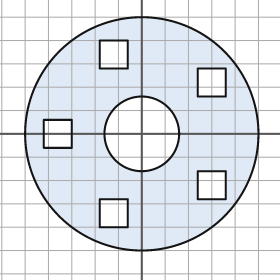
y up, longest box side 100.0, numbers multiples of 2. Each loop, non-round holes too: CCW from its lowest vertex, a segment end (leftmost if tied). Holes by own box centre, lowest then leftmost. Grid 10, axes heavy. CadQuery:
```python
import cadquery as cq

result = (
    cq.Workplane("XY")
    .moveTo(0.0, 0.0)
    .circle(50.0)
    .moveTo(-18.0, -40.0)
    .lineTo(-6.0, -40.0)
    .lineTo(-6.0, -28.0)
    .lineTo(-18.0, -28.0)
    .close()
    .moveTo(24.0, -28.0)
    .lineTo(36.0, -28.0)
    .lineTo(36.0, -16.0)
    .lineTo(24.0, -16.0)
    .close()
    .moveTo(-42.0, -6.0)
    .lineTo(-30.0, -6.0)
    .lineTo(-30.0, 6.0)
    .lineTo(-42.0, 6.0)
    .close()
    .moveTo(0.0, 0.0)
    .circle(16.0)
    .moveTo(24.0, 16.0)
    .lineTo(36.0, 16.0)
    .lineTo(36.0, 28.0)
    .lineTo(24.0, 28.0)
    .close()
    .moveTo(-18.0, 28.0)
    .lineTo(-6.0, 28.0)
    .lineTo(-6.0, 40.0)
    .lineTo(-18.0, 40.0)
    .close()
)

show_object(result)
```